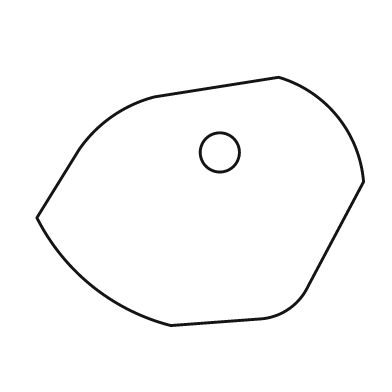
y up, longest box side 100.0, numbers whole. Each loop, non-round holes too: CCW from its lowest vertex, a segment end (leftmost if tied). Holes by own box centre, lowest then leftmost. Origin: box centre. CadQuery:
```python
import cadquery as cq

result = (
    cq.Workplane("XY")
    .moveTo(-9.0, -38.0)
    .lineTo(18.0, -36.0)
    .threePointArc((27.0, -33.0), (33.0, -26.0))
    .lineTo(50.0, 6.0)
    .threePointArc((42.0, 26.0), (24.0, 38.0))
    .lineTo(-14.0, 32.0)
    .threePointArc((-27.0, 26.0), (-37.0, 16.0))
    .lineTo(-50.0, -5.0)
    .threePointArc((-33.0, -26.0), (-9.0, -38.0))
    .close()
    .moveTo(6.0, 15.0)
    .circle(6.0)
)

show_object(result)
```